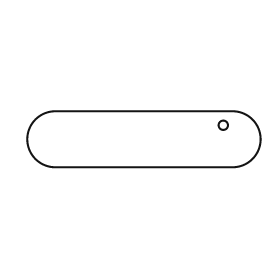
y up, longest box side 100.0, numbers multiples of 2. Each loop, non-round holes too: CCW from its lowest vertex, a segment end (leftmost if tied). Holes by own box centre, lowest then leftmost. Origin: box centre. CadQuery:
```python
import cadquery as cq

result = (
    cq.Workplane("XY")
    .moveTo(-38.0, -12.0)
    .lineTo(38.0, -12.0)
    .threePointArc((50.0, 0.0), (38.0, 12.0))
    .lineTo(-38.0, 12.0)
    .threePointArc((-50.0, 0.0), (-38.0, -12.0))
    .close()
    .moveTo(34.0, 6.0)
    .circle(2.0)
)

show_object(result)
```